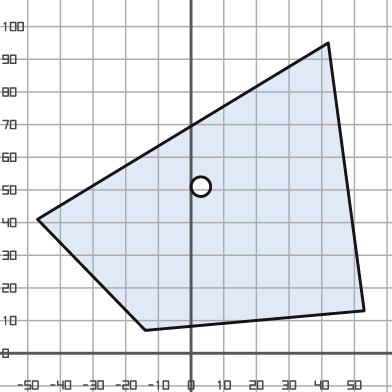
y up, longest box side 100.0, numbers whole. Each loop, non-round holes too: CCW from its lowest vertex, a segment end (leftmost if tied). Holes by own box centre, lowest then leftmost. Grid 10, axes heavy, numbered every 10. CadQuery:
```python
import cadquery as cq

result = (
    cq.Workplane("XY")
    .moveTo(-14.0, 7.0)
    .lineTo(53.0, 13.0)
    .lineTo(42.0, 95.0)
    .lineTo(-47.0, 41.0)
    .close()
    .moveTo(3.0, 51.0)
    .circle(3.0)
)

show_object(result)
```